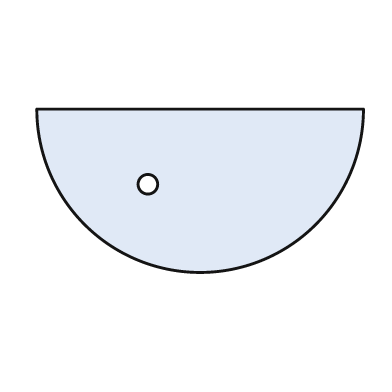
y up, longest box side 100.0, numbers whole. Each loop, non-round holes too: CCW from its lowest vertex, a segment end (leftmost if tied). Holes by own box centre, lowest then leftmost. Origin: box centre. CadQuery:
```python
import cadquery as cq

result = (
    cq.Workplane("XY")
    .moveTo(-50.0, 25.0)
    .threePointArc((0.0, -25.0), (50.0, 25.0))
    .close()
    .moveTo(-16.0, 2.0)
    .circle(3.0)
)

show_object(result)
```